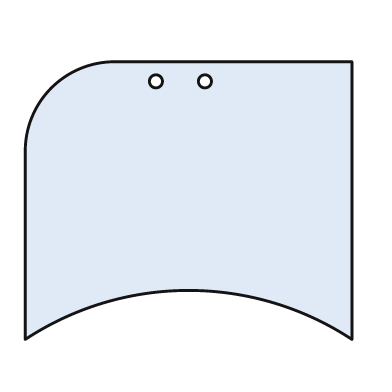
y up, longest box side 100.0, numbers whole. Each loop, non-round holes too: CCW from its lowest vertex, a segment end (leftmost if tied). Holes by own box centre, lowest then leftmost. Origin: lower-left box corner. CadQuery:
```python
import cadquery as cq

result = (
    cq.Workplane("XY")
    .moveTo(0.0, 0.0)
    .threePointArc((50.0, 15.0), (100.0, 0.0))
    .lineTo(100.0, 85.0)
    .lineTo(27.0, 85.0)
    .threePointArc((8.0, 77.0), (0.0, 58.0))
    .close()
    .moveTo(40.0, 79.0)
    .circle(2.0)
    .moveTo(55.0, 79.0)
    .circle(2.0)
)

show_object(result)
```